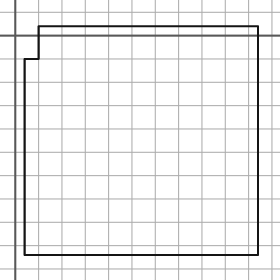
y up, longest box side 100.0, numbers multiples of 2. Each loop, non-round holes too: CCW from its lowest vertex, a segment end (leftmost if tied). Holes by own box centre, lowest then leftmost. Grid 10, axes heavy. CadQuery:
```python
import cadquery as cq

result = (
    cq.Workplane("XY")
    .moveTo(4.0, -94.0)
    .lineTo(104.0, -94.0)
    .lineTo(104.0, 4.0)
    .lineTo(10.0, 4.0)
    .lineTo(10.0, -10.0)
    .lineTo(4.0, -10.0)
    .close()
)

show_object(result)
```